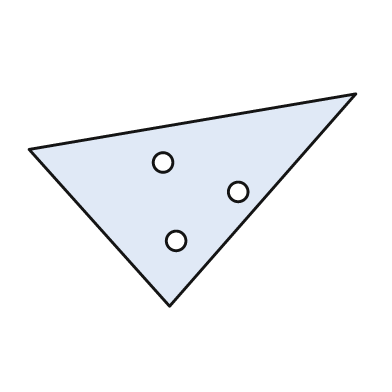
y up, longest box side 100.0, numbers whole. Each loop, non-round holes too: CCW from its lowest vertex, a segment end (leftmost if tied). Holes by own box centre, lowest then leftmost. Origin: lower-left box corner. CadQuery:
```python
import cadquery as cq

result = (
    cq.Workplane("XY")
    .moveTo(43.0, 0.0)
    .lineTo(100.0, 65.0)
    .lineTo(0.0, 48.0)
    .close()
    .moveTo(45.0, 20.0)
    .circle(3.0)
    .moveTo(64.0, 35.0)
    .circle(3.0)
    .moveTo(41.0, 44.0)
    .circle(3.0)
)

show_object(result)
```